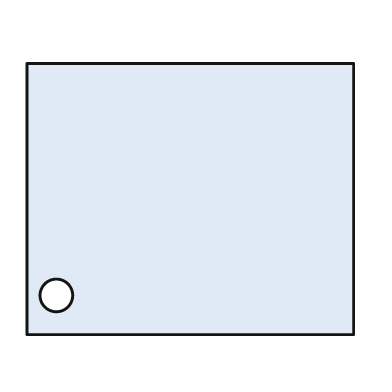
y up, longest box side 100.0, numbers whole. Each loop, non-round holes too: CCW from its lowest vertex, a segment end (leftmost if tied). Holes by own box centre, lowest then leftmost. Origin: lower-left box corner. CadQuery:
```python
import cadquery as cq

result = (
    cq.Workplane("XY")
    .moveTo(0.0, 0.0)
    .lineTo(100.0, 0.0)
    .lineTo(100.0, 83.0)
    .lineTo(0.0, 83.0)
    .close()
    .moveTo(9.0, 12.0)
    .circle(5.0)
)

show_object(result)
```